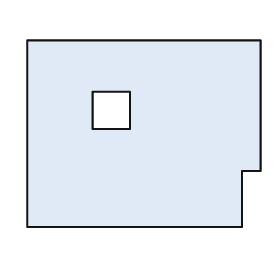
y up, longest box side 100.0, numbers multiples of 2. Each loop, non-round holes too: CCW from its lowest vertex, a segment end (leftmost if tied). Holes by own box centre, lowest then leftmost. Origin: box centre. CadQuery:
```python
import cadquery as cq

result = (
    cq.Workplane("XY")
    .moveTo(-50.0, -40.0)
    .lineTo(42.0, -40.0)
    .lineTo(42.0, -16.0)
    .lineTo(50.0, -16.0)
    .lineTo(50.0, 40.0)
    .lineTo(-50.0, 40.0)
    .close()
    .moveTo(-22.0, 2.0)
    .lineTo(-6.0, 2.0)
    .lineTo(-6.0, 18.0)
    .lineTo(-22.0, 18.0)
    .close()
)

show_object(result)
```